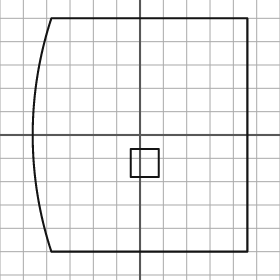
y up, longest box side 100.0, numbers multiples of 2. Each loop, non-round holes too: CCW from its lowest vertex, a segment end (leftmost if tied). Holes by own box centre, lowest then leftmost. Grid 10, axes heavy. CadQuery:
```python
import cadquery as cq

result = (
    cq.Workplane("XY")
    .moveTo(-38.0, -50.0)
    .lineTo(46.0, -50.0)
    .lineTo(46.0, 50.0)
    .lineTo(-38.0, 50.0)
    .threePointArc((-46.0, 0.0), (-38.0, -50.0))
    .close()
    .moveTo(-4.0, -18.0)
    .lineTo(8.0, -18.0)
    .lineTo(8.0, -6.0)
    .lineTo(-4.0, -6.0)
    .close()
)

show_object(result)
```